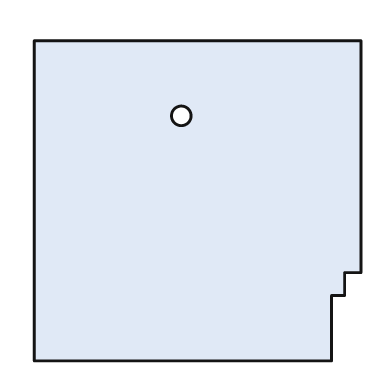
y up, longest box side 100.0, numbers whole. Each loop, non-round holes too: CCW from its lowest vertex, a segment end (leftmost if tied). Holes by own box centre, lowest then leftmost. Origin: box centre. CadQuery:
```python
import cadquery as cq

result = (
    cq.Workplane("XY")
    .moveTo(-50.0, -49.0)
    .lineTo(41.0, -49.0)
    .lineTo(41.0, -29.0)
    .lineTo(45.0, -29.0)
    .lineTo(45.0, -22.0)
    .lineTo(50.0, -22.0)
    .lineTo(50.0, 49.0)
    .lineTo(-50.0, 49.0)
    .close()
    .moveTo(-5.0, 26.0)
    .circle(3.0)
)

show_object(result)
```